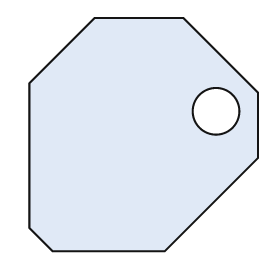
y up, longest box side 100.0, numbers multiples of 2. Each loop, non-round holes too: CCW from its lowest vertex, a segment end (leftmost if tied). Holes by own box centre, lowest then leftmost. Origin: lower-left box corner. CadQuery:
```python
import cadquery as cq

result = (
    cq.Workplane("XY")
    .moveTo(10.0, 0.0)
    .lineTo(58.0, 0.0)
    .lineTo(98.0, 40.0)
    .lineTo(98.0, 68.0)
    .lineTo(66.0, 100.0)
    .lineTo(28.0, 100.0)
    .lineTo(0.0, 72.0)
    .lineTo(0.0, 10.0)
    .close()
    .moveTo(80.0, 60.0)
    .circle(10.0)
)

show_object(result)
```